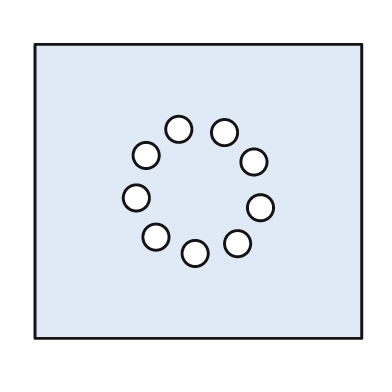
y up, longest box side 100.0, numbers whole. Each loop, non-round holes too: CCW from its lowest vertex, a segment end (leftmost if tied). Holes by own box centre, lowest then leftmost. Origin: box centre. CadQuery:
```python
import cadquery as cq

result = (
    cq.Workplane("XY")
    .moveTo(-50.0, -45.0)
    .lineTo(50.0, -45.0)
    .lineTo(50.0, 45.0)
    .lineTo(-50.0, 45.0)
    .close()
    .moveTo(-1.0, -19.0)
    .circle(4.0)
    .moveTo(12.0, -16.0)
    .circle(4.0)
    .moveTo(-13.0, -14.0)
    .circle(4.0)
    .moveTo(19.0, -5.0)
    .circle(4.0)
    .moveTo(-19.0, -2.0)
    .circle(4.0)
    .moveTo(17.0, 9.0)
    .circle(4.0)
    .moveTo(-16.0, 11.0)
    .circle(4.0)
    .moveTo(8.0, 18.0)
    .circle(4.0)
    .moveTo(-6.0, 19.0)
    .circle(4.0)
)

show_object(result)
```